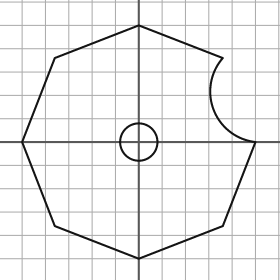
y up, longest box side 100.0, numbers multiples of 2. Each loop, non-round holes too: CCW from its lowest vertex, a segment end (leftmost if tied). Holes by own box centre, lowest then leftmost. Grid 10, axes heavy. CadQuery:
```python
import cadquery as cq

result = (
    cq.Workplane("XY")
    .moveTo(0.0, -50.0)
    .lineTo(36.0, -36.0)
    .lineTo(50.0, 0.0)
    .threePointArc((32.0, 14.0), (36.0, 36.0))
    .lineTo(0.0, 50.0)
    .lineTo(-36.0, 36.0)
    .lineTo(-50.0, 0.0)
    .lineTo(-36.0, -36.0)
    .close()
    .moveTo(0.0, 0.0)
    .circle(8.0)
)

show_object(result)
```